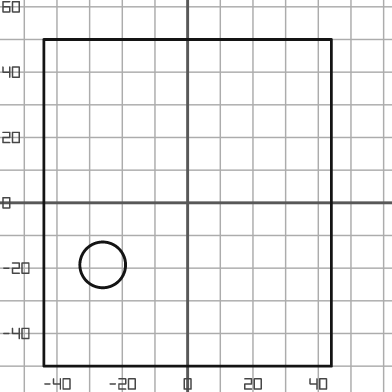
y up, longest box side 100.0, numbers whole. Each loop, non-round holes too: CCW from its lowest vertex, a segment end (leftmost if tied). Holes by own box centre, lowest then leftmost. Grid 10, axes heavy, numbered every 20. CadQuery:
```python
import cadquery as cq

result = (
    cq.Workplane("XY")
    .moveTo(-44.0, -50.0)
    .lineTo(44.0, -50.0)
    .lineTo(44.0, 50.0)
    .lineTo(-44.0, 50.0)
    .close()
    .moveTo(-26.0, -19.0)
    .circle(7.0)
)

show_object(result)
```